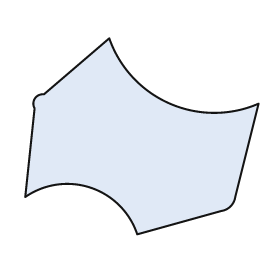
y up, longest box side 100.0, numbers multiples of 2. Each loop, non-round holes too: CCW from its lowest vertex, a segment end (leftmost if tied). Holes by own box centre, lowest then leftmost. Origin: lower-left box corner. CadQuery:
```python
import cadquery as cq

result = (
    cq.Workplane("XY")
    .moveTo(48.0, 0.0)
    .lineTo(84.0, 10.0)
    .threePointArc((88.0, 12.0), (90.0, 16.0))
    .lineTo(100.0, 56.0)
    .threePointArc((62.0, 56.0), (36.0, 84.0))
    .lineTo(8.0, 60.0)
    .threePointArc((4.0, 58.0), (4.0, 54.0))
    .lineTo(0.0, 16.0)
    .threePointArc((28.0, 20.0), (48.0, 0.0))
    .close()
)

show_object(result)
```